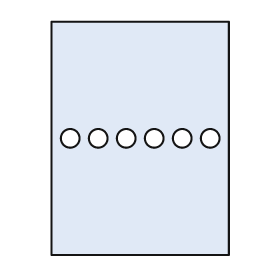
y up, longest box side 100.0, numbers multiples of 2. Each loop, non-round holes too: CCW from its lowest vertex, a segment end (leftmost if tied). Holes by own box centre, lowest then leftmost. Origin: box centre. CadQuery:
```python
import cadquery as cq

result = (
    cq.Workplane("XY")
    .moveTo(-38.0, -50.0)
    .lineTo(38.0, -50.0)
    .lineTo(38.0, 50.0)
    .lineTo(-38.0, 50.0)
    .close()
    .moveTo(-30.0, 0.0)
    .circle(4.0)
    .moveTo(-18.0, 0.0)
    .circle(4.0)
    .moveTo(-6.0, 0.0)
    .circle(4.0)
    .moveTo(6.0, 0.0)
    .circle(4.0)
    .moveTo(18.0, 0.0)
    .circle(4.0)
    .moveTo(30.0, 0.0)
    .circle(4.0)
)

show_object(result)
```